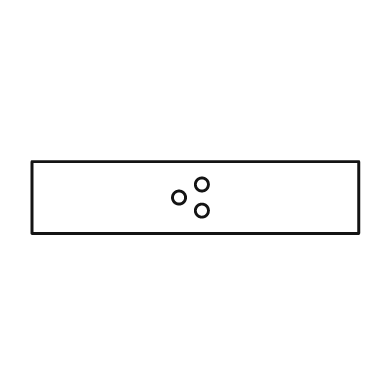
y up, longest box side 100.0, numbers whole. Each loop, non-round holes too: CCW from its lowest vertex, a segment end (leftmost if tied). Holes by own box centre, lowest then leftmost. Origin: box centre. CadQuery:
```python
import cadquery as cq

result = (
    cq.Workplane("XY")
    .moveTo(-50.0, -11.0)
    .lineTo(50.0, -11.0)
    .lineTo(50.0, 11.0)
    .lineTo(-50.0, 11.0)
    .close()
    .moveTo(2.0, -4.0)
    .circle(2.0)
    .moveTo(-5.0, 0.0)
    .circle(2.0)
    .moveTo(2.0, 4.0)
    .circle(2.0)
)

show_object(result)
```